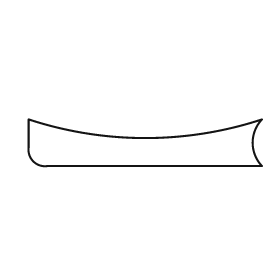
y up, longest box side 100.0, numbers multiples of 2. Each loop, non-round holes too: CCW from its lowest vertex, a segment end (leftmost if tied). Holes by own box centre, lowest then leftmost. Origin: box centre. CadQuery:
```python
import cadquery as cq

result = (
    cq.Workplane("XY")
    .moveTo(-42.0, -10.0)
    .lineTo(50.0, -10.0)
    .threePointArc((46.0, 0.0), (50.0, 10.0))
    .threePointArc((0.0, 2.0), (-50.0, 10.0))
    .lineTo(-50.0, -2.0)
    .threePointArc((-48.0, -8.0), (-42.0, -10.0))
    .close()
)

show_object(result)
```